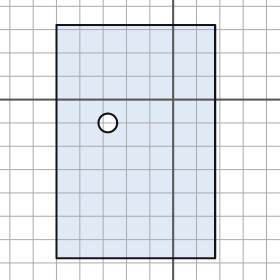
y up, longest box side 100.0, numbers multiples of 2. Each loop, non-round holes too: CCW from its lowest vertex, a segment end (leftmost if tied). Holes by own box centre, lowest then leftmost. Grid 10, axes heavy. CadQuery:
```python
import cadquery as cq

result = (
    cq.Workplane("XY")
    .moveTo(-50.0, -68.0)
    .lineTo(18.0, -68.0)
    .lineTo(18.0, 32.0)
    .lineTo(-50.0, 32.0)
    .close()
    .moveTo(-28.0, -10.0)
    .circle(4.0)
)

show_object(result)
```